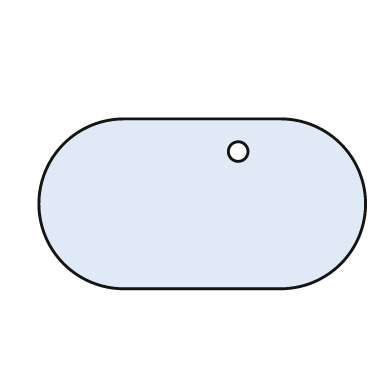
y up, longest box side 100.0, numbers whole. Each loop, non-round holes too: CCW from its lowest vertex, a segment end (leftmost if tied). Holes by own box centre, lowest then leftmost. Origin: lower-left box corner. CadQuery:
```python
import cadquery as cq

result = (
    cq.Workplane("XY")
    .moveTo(26.0, 0.0)
    .lineTo(74.0, 0.0)
    .threePointArc((100.0, 26.0), (74.0, 52.0))
    .lineTo(26.0, 52.0)
    .threePointArc((0.0, 26.0), (26.0, 0.0))
    .close()
    .moveTo(61.0, 42.0)
    .circle(3.0)
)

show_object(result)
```